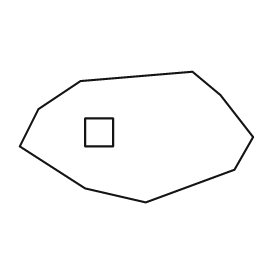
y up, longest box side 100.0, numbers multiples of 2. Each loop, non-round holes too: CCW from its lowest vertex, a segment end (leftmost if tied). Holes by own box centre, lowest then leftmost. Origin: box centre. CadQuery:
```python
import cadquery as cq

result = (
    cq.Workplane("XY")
    .moveTo(4.0, -28.0)
    .lineTo(42.0, -14.0)
    .lineTo(50.0, 0.0)
    .lineTo(36.0, 18.0)
    .lineTo(24.0, 28.0)
    .lineTo(-24.0, 24.0)
    .lineTo(-42.0, 12.0)
    .lineTo(-50.0, -4.0)
    .lineTo(-22.0, -22.0)
    .close()
    .moveTo(-22.0, -4.0)
    .lineTo(-10.0, -4.0)
    .lineTo(-10.0, 8.0)
    .lineTo(-22.0, 8.0)
    .close()
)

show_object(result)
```